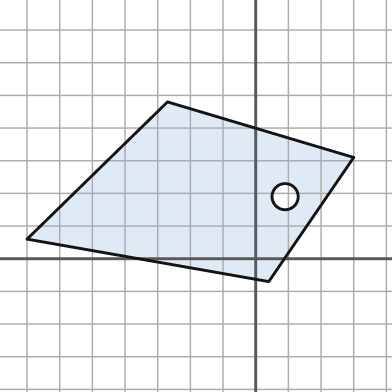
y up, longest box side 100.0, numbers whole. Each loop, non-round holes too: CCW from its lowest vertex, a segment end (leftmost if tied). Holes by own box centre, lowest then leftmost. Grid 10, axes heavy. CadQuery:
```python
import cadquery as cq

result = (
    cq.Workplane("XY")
    .moveTo(4.0, -7.0)
    .lineTo(30.0, 31.0)
    .lineTo(-27.0, 48.0)
    .lineTo(-70.0, 6.0)
    .close()
    .moveTo(9.0, 19.0)
    .circle(4.0)
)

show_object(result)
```